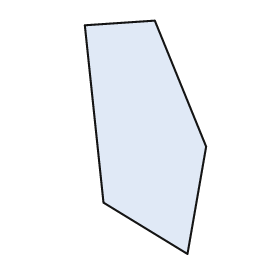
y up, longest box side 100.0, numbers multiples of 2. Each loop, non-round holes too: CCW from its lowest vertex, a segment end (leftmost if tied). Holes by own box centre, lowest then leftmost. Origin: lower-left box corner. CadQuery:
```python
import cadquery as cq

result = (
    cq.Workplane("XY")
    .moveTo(44.0, 0.0)
    .lineTo(52.0, 46.0)
    .lineTo(30.0, 100.0)
    .lineTo(0.0, 98.0)
    .lineTo(8.0, 22.0)
    .close()
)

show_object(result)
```